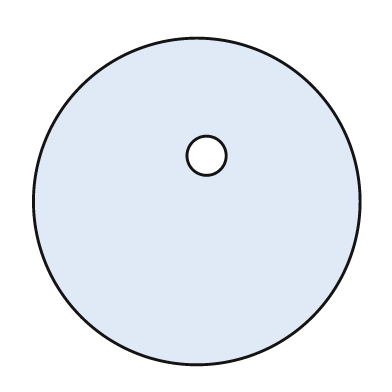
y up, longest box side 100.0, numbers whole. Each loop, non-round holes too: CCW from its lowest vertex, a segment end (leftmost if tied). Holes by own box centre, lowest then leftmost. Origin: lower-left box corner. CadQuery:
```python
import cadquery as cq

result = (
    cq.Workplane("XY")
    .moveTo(50.0, 50.0)
    .circle(50.0)
    .moveTo(53.0, 64.0)
    .circle(6.0)
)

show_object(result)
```